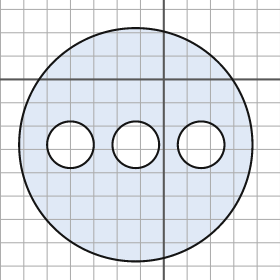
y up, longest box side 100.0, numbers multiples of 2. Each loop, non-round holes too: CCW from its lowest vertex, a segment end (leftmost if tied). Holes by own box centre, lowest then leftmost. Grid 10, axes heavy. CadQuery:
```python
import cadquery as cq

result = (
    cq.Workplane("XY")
    .moveTo(-12.0, -28.0)
    .circle(50.0)
    .moveTo(-40.0, -28.0)
    .circle(10.0)
    .moveTo(-12.0, -28.0)
    .circle(10.0)
    .moveTo(16.0, -28.0)
    .circle(10.0)
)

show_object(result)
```